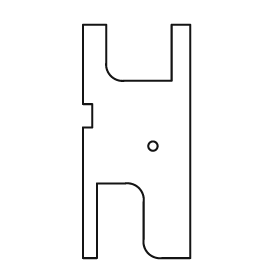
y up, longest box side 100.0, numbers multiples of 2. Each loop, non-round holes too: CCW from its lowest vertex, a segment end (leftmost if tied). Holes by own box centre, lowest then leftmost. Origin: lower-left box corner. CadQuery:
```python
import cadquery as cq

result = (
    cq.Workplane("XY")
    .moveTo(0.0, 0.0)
    .lineTo(6.0, 0.0)
    .lineTo(6.0, 32.0)
    .lineTo(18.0, 32.0)
    .threePointArc((24.0, 30.0), (26.0, 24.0))
    .lineTo(26.0, 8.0)
    .threePointArc((28.0, 2.0), (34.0, 0.0))
    .lineTo(46.0, 0.0)
    .lineTo(46.0, 100.0)
    .lineTo(38.0, 100.0)
    .lineTo(38.0, 76.0)
    .lineTo(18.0, 76.0)
    .threePointArc((12.0, 78.0), (10.0, 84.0))
    .lineTo(10.0, 100.0)
    .lineTo(0.0, 100.0)
    .lineTo(0.0, 66.0)
    .lineTo(4.0, 66.0)
    .lineTo(4.0, 56.0)
    .lineTo(0.0, 56.0)
    .close()
    .moveTo(30.0, 48.0)
    .circle(2.0)
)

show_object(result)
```